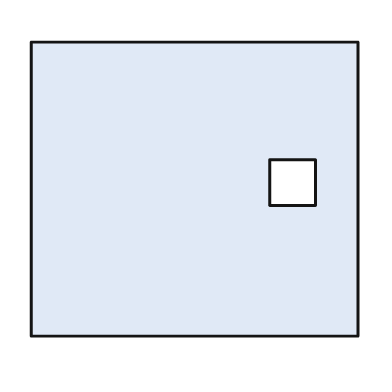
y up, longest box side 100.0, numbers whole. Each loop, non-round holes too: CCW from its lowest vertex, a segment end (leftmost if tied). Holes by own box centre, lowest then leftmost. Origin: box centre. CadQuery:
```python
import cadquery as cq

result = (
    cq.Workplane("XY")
    .moveTo(-50.0, -45.0)
    .lineTo(50.0, -45.0)
    .lineTo(50.0, 45.0)
    .lineTo(-50.0, 45.0)
    .close()
    .moveTo(23.0, -5.0)
    .lineTo(37.0, -5.0)
    .lineTo(37.0, 9.0)
    .lineTo(23.0, 9.0)
    .close()
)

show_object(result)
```